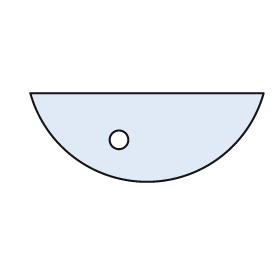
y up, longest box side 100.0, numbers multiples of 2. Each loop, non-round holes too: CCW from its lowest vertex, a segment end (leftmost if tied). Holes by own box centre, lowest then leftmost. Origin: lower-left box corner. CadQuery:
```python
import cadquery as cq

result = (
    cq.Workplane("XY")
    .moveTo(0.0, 38.0)
    .threePointArc((50.0, 0.0), (100.0, 38.0))
    .close()
    .moveTo(38.0, 18.0)
    .circle(4.0)
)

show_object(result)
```